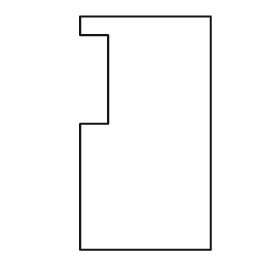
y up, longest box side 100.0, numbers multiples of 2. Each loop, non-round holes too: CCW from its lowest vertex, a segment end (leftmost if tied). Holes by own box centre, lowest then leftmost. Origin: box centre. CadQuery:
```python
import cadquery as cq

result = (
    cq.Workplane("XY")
    .moveTo(-28.0, -50.0)
    .lineTo(28.0, -50.0)
    .lineTo(28.0, 50.0)
    .lineTo(-28.0, 50.0)
    .lineTo(-28.0, 42.0)
    .lineTo(-16.0, 42.0)
    .lineTo(-16.0, 4.0)
    .lineTo(-28.0, 4.0)
    .close()
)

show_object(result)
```